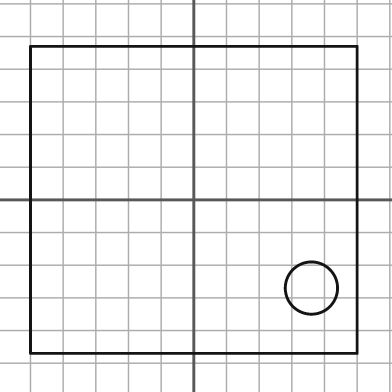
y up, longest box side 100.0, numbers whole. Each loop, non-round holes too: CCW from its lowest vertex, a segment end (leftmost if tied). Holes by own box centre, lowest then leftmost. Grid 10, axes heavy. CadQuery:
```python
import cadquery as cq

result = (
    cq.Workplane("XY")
    .moveTo(-50.0, -47.0)
    .lineTo(50.0, -47.0)
    .lineTo(50.0, 47.0)
    .lineTo(-50.0, 47.0)
    .close()
    .moveTo(36.0, -27.0)
    .circle(8.0)
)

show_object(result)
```